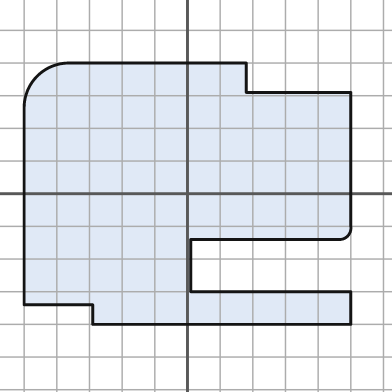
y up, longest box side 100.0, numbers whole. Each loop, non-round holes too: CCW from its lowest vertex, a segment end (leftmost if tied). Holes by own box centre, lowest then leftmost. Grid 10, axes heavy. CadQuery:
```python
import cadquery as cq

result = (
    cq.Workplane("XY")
    .moveTo(-29.0, -40.0)
    .lineTo(50.0, -40.0)
    .lineTo(50.0, -30.0)
    .lineTo(1.0, -30.0)
    .lineTo(1.0, -14.0)
    .lineTo(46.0, -14.0)
    .threePointArc((49.0, -13.0), (50.0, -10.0))
    .lineTo(50.0, 31.0)
    .lineTo(18.0, 31.0)
    .lineTo(18.0, 40.0)
    .lineTo(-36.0, 40.0)
    .threePointArc((-46.0, 36.0), (-50.0, 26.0))
    .lineTo(-50.0, -34.0)
    .lineTo(-29.0, -34.0)
    .close()
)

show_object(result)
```